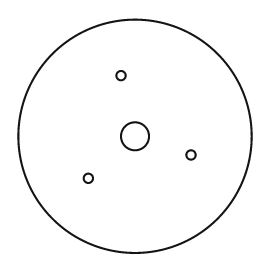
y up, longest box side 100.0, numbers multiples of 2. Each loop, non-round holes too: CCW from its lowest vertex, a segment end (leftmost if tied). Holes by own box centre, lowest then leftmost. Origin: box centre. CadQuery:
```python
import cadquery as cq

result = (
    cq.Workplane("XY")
    .moveTo(0.0, 0.0)
    .circle(50.0)
    .moveTo(-20.0, -18.0)
    .circle(2.0)
    .moveTo(24.0, -8.0)
    .circle(2.0)
    .moveTo(0.0, 0.0)
    .circle(6.0)
    .moveTo(-6.0, 26.0)
    .circle(2.0)
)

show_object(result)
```